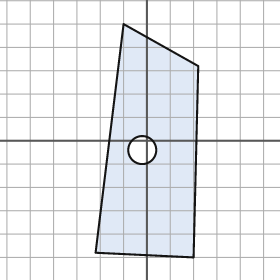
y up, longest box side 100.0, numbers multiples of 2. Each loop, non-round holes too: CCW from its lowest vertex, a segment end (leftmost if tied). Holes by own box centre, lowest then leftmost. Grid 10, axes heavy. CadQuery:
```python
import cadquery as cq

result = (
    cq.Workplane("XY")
    .moveTo(20.0, -50.0)
    .lineTo(22.0, 32.0)
    .lineTo(-10.0, 50.0)
    .lineTo(-22.0, -48.0)
    .close()
    .moveTo(-2.0, -4.0)
    .circle(6.0)
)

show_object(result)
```